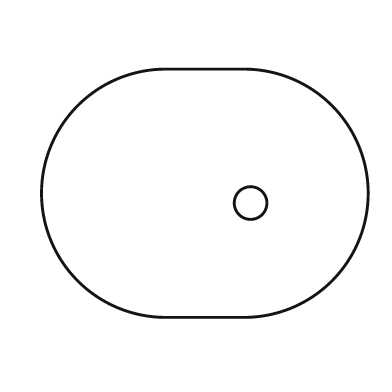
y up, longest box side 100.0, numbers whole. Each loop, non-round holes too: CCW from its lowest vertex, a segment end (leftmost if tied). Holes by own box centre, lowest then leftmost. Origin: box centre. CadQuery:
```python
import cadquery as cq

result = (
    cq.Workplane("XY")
    .moveTo(-12.0, -38.0)
    .lineTo(12.0, -38.0)
    .threePointArc((50.0, 0.0), (12.0, 38.0))
    .lineTo(-12.0, 38.0)
    .threePointArc((-50.0, 0.0), (-12.0, -38.0))
    .close()
    .moveTo(14.0, -3.0)
    .circle(5.0)
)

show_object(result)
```